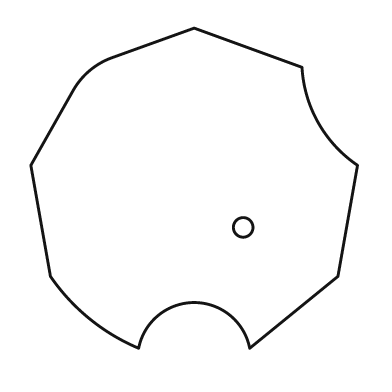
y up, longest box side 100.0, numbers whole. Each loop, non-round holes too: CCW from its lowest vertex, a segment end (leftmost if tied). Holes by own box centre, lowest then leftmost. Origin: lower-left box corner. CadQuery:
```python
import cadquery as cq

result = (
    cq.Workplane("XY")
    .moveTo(33.0, 0.0)
    .threePointArc((50.0, 14.0), (67.0, 0.0))
    .lineTo(94.0, 22.0)
    .lineTo(100.0, 56.0)
    .threePointArc((88.0, 69.0), (83.0, 86.0))
    .lineTo(50.0, 98.0)
    .lineTo(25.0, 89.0)
    .threePointArc((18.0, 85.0), (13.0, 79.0))
    .lineTo(0.0, 56.0)
    .lineTo(6.0, 22.0)
    .threePointArc((18.0, 9.0), (33.0, 0.0))
    .close()
    .moveTo(65.0, 37.0)
    .circle(3.0)
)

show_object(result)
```